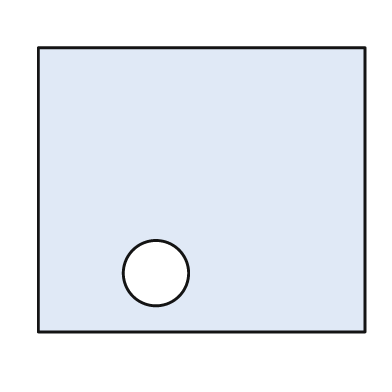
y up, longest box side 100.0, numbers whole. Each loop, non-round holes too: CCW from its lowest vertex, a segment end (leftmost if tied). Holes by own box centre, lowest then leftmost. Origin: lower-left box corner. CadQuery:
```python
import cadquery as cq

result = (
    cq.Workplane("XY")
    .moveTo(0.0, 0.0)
    .lineTo(100.0, 0.0)
    .lineTo(100.0, 87.0)
    .lineTo(0.0, 87.0)
    .close()
    .moveTo(36.0, 18.0)
    .circle(10.0)
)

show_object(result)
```